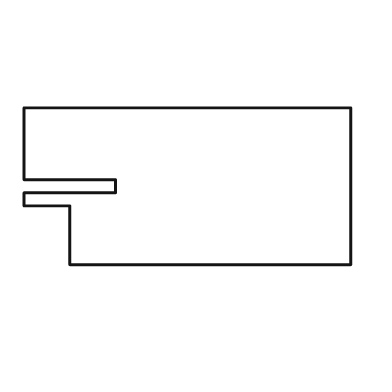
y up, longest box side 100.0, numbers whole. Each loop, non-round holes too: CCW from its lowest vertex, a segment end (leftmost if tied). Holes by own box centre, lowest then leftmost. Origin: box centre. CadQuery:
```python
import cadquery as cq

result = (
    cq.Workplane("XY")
    .moveTo(-36.0, -24.0)
    .lineTo(50.0, -24.0)
    .lineTo(50.0, 24.0)
    .lineTo(-50.0, 24.0)
    .lineTo(-50.0, 2.0)
    .lineTo(-22.0, 2.0)
    .lineTo(-22.0, -2.0)
    .lineTo(-50.0, -2.0)
    .lineTo(-50.0, -6.0)
    .lineTo(-36.0, -6.0)
    .close()
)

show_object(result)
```